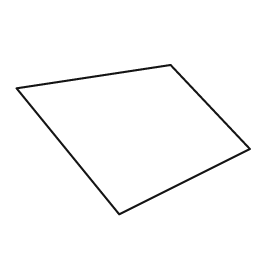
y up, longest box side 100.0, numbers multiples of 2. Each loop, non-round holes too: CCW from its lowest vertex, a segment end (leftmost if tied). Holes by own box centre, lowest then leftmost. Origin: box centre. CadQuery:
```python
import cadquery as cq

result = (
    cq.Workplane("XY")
    .moveTo(-6.0, -32.0)
    .lineTo(50.0, -4.0)
    .lineTo(16.0, 32.0)
    .lineTo(-50.0, 22.0)
    .close()
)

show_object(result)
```